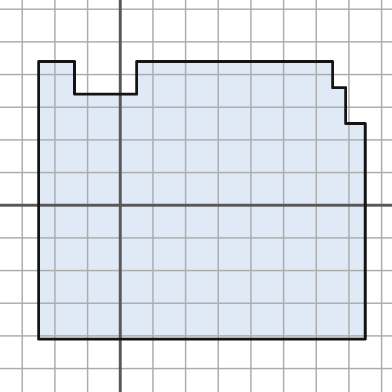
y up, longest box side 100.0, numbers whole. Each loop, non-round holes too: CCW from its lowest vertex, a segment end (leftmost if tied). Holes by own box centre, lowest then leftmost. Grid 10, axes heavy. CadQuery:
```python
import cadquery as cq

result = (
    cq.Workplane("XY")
    .moveTo(-25.0, -41.0)
    .lineTo(75.0, -41.0)
    .lineTo(75.0, 25.0)
    .lineTo(69.0, 25.0)
    .lineTo(69.0, 36.0)
    .lineTo(65.0, 36.0)
    .lineTo(65.0, 44.0)
    .lineTo(5.0, 44.0)
    .lineTo(5.0, 34.0)
    .lineTo(-14.0, 34.0)
    .lineTo(-14.0, 44.0)
    .lineTo(-25.0, 44.0)
    .close()
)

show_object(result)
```